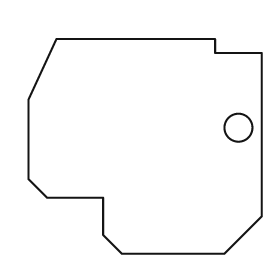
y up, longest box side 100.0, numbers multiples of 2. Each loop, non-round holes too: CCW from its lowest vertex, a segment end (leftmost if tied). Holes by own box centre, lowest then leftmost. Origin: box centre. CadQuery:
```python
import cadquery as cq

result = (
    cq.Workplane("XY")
    .moveTo(-10.0, -46.0)
    .lineTo(34.0, -46.0)
    .lineTo(50.0, -30.0)
    .lineTo(50.0, 40.0)
    .lineTo(30.0, 40.0)
    .lineTo(30.0, 46.0)
    .lineTo(-38.0, 46.0)
    .lineTo(-50.0, 20.0)
    .lineTo(-50.0, -14.0)
    .lineTo(-42.0, -22.0)
    .lineTo(-18.0, -22.0)
    .lineTo(-18.0, -38.0)
    .close()
    .moveTo(40.0, 8.0)
    .circle(6.0)
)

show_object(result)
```